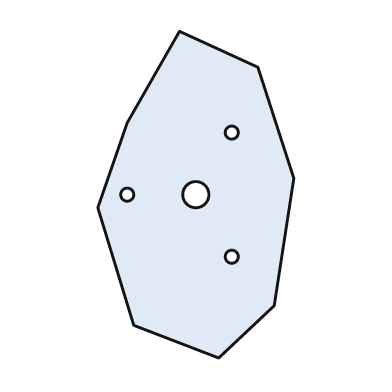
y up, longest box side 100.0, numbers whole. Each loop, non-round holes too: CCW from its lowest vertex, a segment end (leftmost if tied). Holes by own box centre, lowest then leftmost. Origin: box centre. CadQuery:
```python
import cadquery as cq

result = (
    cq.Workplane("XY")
    .moveTo(7.0, -50.0)
    .lineTo(24.0, -34.0)
    .lineTo(30.0, 5.0)
    .lineTo(19.0, 39.0)
    .lineTo(-5.0, 50.0)
    .lineTo(-21.0, 22.0)
    .lineTo(-30.0, -4.0)
    .lineTo(-19.0, -40.0)
    .close()
    .moveTo(11.0, -19.0)
    .circle(2.0)
    .moveTo(-21.0, 0.0)
    .circle(2.0)
    .moveTo(0.0, 0.0)
    .circle(4.0)
    .moveTo(11.0, 19.0)
    .circle(2.0)
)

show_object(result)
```